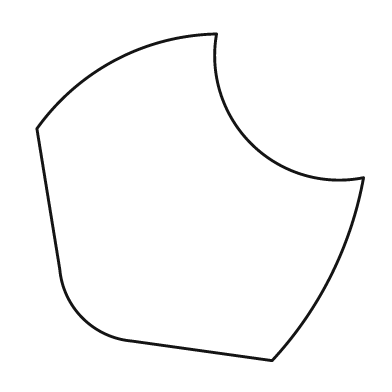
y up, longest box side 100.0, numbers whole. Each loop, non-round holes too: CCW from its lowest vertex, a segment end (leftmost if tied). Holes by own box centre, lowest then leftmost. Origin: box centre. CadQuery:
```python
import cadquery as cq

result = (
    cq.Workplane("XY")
    .moveTo(22.0, -50.0)
    .threePointArc((40.0, -24.0), (50.0, 6.0))
    .threePointArc((16.0, 16.0), (5.0, 50.0))
    .threePointArc((-26.0, 42.0), (-50.0, 21.0))
    .lineTo(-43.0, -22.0)
    .threePointArc((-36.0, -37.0), (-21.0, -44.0))
    .close()
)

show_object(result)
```